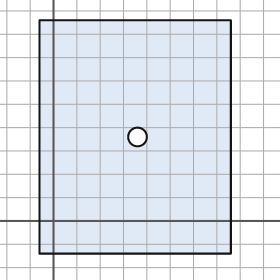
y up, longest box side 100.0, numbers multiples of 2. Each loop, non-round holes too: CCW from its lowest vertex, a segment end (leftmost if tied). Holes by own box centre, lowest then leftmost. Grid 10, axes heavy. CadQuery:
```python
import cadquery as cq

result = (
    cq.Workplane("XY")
    .moveTo(-6.0, -14.0)
    .lineTo(76.0, -14.0)
    .lineTo(76.0, 86.0)
    .lineTo(-6.0, 86.0)
    .close()
    .moveTo(36.0, 36.0)
    .circle(4.0)
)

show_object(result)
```